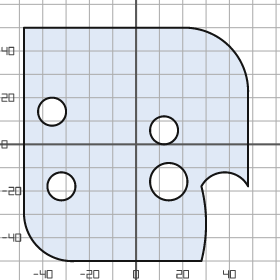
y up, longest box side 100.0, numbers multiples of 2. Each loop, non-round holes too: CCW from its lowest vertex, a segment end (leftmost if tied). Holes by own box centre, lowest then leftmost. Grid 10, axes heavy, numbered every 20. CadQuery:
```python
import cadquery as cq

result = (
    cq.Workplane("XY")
    .moveTo(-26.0, -50.0)
    .lineTo(28.0, -50.0)
    .threePointArc((30.0, -34.0), (28.0, -18.0))
    .threePointArc((38.0, -12.0), (48.0, -18.0))
    .lineTo(48.0, 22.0)
    .threePointArc((40.0, 42.0), (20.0, 50.0))
    .lineTo(-48.0, 50.0)
    .lineTo(-48.0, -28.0)
    .threePointArc((-42.0, -44.0), (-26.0, -50.0))
    .close()
    .moveTo(-32.0, -18.0)
    .circle(6.0)
    .moveTo(14.0, -16.0)
    .circle(8.0)
    .moveTo(12.0, 6.0)
    .circle(6.0)
    .moveTo(-36.0, 14.0)
    .circle(6.0)
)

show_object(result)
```